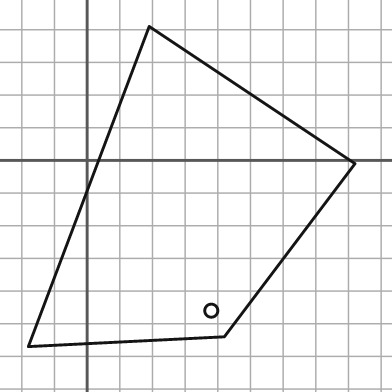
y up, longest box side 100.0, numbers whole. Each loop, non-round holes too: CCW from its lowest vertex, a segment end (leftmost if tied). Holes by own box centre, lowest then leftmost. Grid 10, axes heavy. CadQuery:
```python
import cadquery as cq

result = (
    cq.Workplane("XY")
    .moveTo(-18.0, -57.0)
    .lineTo(42.0, -54.0)
    .lineTo(82.0, -1.0)
    .lineTo(19.0, 41.0)
    .close()
    .moveTo(38.0, -46.0)
    .circle(2.0)
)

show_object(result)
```